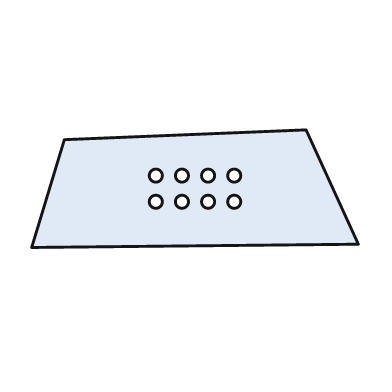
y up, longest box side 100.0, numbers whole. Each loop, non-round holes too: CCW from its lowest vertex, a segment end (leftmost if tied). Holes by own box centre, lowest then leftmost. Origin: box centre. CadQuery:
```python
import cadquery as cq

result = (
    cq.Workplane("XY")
    .moveTo(-50.0, -18.0)
    .lineTo(50.0, -17.0)
    .lineTo(34.0, 18.0)
    .lineTo(-40.0, 15.0)
    .close()
    .moveTo(-12.0, -4.0)
    .circle(2.0)
    .moveTo(-4.0, -4.0)
    .circle(2.0)
    .moveTo(4.0, -4.0)
    .circle(2.0)
    .moveTo(12.0, -4.0)
    .circle(2.0)
    .moveTo(-12.0, 4.0)
    .circle(2.0)
    .moveTo(-4.0, 4.0)
    .circle(2.0)
    .moveTo(4.0, 4.0)
    .circle(2.0)
    .moveTo(12.0, 4.0)
    .circle(2.0)
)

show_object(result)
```